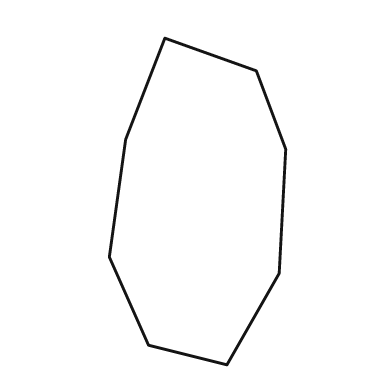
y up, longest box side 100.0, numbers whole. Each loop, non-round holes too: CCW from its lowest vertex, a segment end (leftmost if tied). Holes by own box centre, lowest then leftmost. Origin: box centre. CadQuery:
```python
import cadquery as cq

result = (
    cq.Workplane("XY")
    .moveTo(9.0, -50.0)
    .lineTo(25.0, -22.0)
    .lineTo(27.0, 16.0)
    .lineTo(18.0, 40.0)
    .lineTo(-10.0, 50.0)
    .lineTo(-22.0, 19.0)
    .lineTo(-27.0, -17.0)
    .lineTo(-15.0, -44.0)
    .close()
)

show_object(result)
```